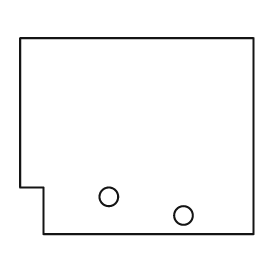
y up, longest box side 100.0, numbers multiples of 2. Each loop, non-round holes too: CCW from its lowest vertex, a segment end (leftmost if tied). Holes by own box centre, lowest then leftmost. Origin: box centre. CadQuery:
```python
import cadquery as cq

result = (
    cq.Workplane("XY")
    .moveTo(-40.0, -42.0)
    .lineTo(50.0, -42.0)
    .lineTo(50.0, 42.0)
    .lineTo(-50.0, 42.0)
    .lineTo(-50.0, -22.0)
    .lineTo(-40.0, -22.0)
    .close()
    .moveTo(20.0, -34.0)
    .circle(4.0)
    .moveTo(-12.0, -26.0)
    .circle(4.0)
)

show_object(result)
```